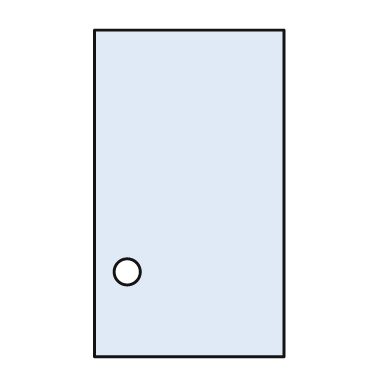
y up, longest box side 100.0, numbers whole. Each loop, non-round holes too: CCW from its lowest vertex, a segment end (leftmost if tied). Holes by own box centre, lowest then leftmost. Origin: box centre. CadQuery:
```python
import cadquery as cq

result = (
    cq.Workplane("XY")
    .moveTo(-29.0, -50.0)
    .lineTo(29.0, -50.0)
    .lineTo(29.0, 50.0)
    .lineTo(-29.0, 50.0)
    .close()
    .moveTo(-19.0, -24.0)
    .circle(4.0)
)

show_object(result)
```